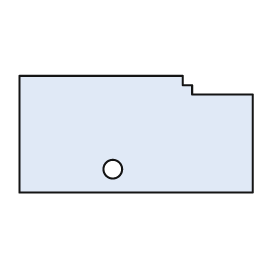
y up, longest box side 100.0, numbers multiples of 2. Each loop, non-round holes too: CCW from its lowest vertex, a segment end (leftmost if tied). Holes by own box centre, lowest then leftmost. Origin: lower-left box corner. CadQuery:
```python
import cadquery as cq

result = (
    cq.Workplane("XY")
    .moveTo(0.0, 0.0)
    .lineTo(100.0, 0.0)
    .lineTo(100.0, 42.0)
    .lineTo(74.0, 42.0)
    .lineTo(74.0, 46.0)
    .lineTo(70.0, 46.0)
    .lineTo(70.0, 50.0)
    .lineTo(0.0, 50.0)
    .close()
    .moveTo(40.0, 10.0)
    .circle(4.0)
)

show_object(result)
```